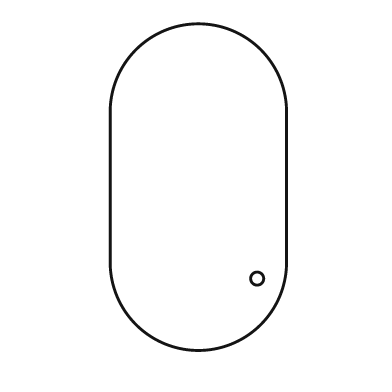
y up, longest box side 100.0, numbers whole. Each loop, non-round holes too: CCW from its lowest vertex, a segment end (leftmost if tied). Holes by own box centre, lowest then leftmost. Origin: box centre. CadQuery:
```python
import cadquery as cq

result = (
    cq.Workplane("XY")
    .moveTo(-27.0, -23.0)
    .threePointArc((0.0, -50.0), (27.0, -23.0))
    .lineTo(27.0, 23.0)
    .threePointArc((0.0, 50.0), (-27.0, 23.0))
    .close()
    .moveTo(18.0, -28.0)
    .circle(2.0)
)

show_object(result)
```